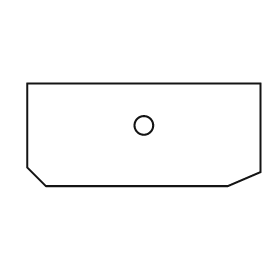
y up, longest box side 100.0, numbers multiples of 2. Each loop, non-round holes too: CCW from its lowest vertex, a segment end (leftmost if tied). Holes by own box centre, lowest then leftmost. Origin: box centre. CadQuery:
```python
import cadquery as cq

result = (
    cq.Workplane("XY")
    .moveTo(-42.0, -22.0)
    .lineTo(36.0, -22.0)
    .lineTo(50.0, -16.0)
    .lineTo(50.0, 22.0)
    .lineTo(-50.0, 22.0)
    .lineTo(-50.0, -14.0)
    .close()
    .moveTo(0.0, 4.0)
    .circle(4.0)
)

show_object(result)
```